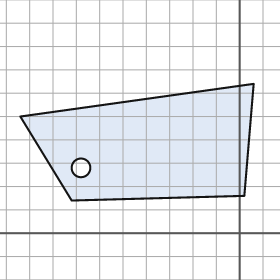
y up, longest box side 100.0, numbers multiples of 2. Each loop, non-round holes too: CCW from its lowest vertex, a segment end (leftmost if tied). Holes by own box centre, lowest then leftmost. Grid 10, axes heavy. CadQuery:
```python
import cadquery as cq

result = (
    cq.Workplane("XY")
    .moveTo(-72.0, 14.0)
    .lineTo(2.0, 16.0)
    .lineTo(6.0, 64.0)
    .lineTo(-94.0, 50.0)
    .close()
    .moveTo(-68.0, 28.0)
    .circle(4.0)
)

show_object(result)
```